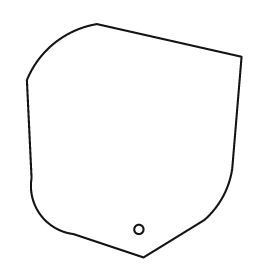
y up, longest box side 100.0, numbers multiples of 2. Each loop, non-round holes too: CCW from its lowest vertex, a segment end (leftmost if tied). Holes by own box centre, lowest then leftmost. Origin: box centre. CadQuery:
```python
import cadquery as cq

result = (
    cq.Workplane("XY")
    .moveTo(4.0, -50.0)
    .lineTo(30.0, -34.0)
    .threePointArc((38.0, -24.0), (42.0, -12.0))
    .lineTo(46.0, 36.0)
    .lineTo(-16.0, 50.0)
    .threePointArc((-34.0, 42.0), (-46.0, 26.0))
    .lineTo(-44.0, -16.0)
    .threePointArc((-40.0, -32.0), (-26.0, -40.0))
    .close()
    .moveTo(2.0, -38.0)
    .circle(2.0)
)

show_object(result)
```